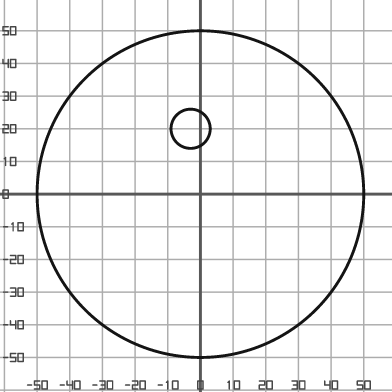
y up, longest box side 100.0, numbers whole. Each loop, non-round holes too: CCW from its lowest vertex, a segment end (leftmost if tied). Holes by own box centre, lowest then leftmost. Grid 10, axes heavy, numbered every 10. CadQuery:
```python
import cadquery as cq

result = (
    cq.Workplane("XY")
    .moveTo(0.0, 0.0)
    .circle(50.0)
    .moveTo(-3.0, 20.0)
    .circle(6.0)
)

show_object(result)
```